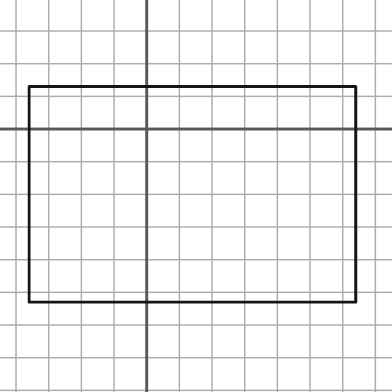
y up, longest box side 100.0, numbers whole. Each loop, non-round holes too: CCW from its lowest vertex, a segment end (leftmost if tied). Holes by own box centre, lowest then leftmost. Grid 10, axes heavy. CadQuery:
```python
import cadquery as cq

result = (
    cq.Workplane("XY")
    .moveTo(-36.0, -53.0)
    .lineTo(64.0, -53.0)
    .lineTo(64.0, 13.0)
    .lineTo(-36.0, 13.0)
    .close()
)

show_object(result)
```